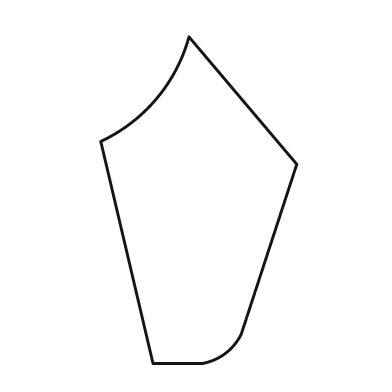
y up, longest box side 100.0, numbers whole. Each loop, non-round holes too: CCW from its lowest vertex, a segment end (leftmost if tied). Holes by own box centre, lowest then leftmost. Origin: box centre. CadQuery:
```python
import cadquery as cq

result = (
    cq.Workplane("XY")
    .moveTo(-14.0, -50.0)
    .lineTo(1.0, -50.0)
    .threePointArc((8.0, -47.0), (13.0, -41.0))
    .lineTo(30.0, 11.0)
    .lineTo(-3.0, 50.0)
    .threePointArc((-13.0, 31.0), (-30.0, 18.0))
    .close()
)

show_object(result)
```